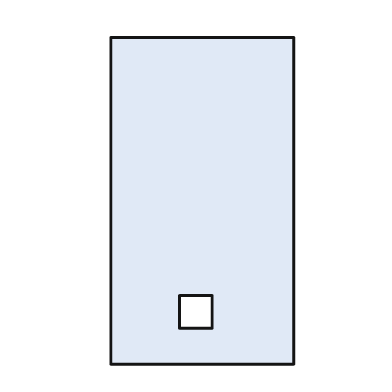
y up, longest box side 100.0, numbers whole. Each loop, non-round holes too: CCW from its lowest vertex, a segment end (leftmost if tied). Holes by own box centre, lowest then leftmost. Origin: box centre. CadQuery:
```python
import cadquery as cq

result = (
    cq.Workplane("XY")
    .moveTo(-28.0, -50.0)
    .lineTo(28.0, -50.0)
    .lineTo(28.0, 50.0)
    .lineTo(-28.0, 50.0)
    .close()
    .moveTo(-7.0, -39.0)
    .lineTo(3.0, -39.0)
    .lineTo(3.0, -29.0)
    .lineTo(-7.0, -29.0)
    .close()
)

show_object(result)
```